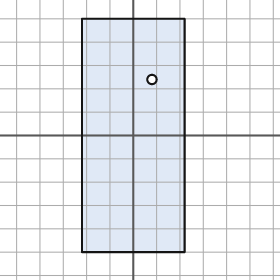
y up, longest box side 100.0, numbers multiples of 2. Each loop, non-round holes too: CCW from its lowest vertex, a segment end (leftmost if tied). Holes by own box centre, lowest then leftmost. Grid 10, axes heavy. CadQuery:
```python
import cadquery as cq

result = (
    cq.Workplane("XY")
    .moveTo(-22.0, -50.0)
    .lineTo(22.0, -50.0)
    .lineTo(22.0, 50.0)
    .lineTo(-22.0, 50.0)
    .close()
    .moveTo(8.0, 24.0)
    .circle(2.0)
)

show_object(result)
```